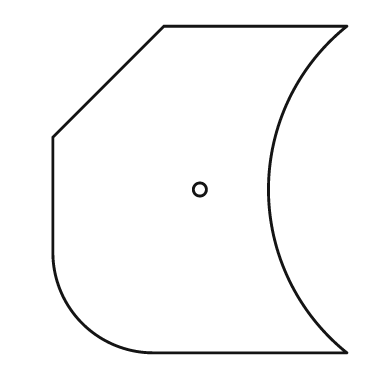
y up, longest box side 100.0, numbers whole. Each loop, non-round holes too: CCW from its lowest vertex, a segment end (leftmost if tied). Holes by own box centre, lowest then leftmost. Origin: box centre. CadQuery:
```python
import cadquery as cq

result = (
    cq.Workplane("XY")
    .moveTo(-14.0, -50.0)
    .lineTo(45.0, -50.0)
    .threePointArc((21.0, 0.0), (45.0, 50.0))
    .lineTo(-11.0, 50.0)
    .lineTo(-45.0, 16.0)
    .lineTo(-45.0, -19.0)
    .threePointArc((-36.0, -41.0), (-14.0, -50.0))
    .close()
    .moveTo(0.0, 0.0)
    .circle(2.0)
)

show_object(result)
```